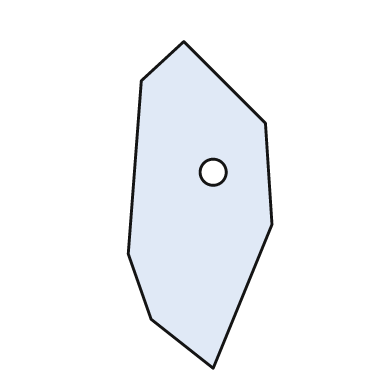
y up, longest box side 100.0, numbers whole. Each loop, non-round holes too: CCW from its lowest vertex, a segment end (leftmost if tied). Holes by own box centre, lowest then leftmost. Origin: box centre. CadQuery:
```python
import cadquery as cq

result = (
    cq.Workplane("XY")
    .moveTo(4.0, -50.0)
    .lineTo(22.0, -6.0)
    .lineTo(20.0, 25.0)
    .lineTo(-5.0, 50.0)
    .lineTo(-18.0, 38.0)
    .lineTo(-22.0, -15.0)
    .lineTo(-15.0, -35.0)
    .close()
    .moveTo(4.0, 10.0)
    .circle(4.0)
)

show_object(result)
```